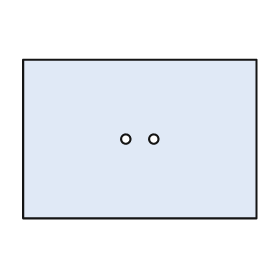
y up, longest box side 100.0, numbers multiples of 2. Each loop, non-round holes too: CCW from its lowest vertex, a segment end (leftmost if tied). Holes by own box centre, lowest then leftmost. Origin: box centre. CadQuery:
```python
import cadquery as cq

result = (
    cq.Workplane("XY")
    .moveTo(-50.0, -34.0)
    .lineTo(50.0, -34.0)
    .lineTo(50.0, 34.0)
    .lineTo(-50.0, 34.0)
    .close()
    .moveTo(-6.0, 0.0)
    .circle(2.0)
    .moveTo(6.0, 0.0)
    .circle(2.0)
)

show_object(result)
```